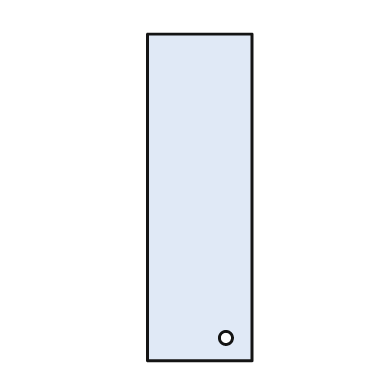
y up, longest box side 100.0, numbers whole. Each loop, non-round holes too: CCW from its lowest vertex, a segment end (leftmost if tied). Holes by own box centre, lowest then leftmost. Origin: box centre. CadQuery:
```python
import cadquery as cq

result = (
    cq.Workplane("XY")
    .moveTo(-16.0, -50.0)
    .lineTo(16.0, -50.0)
    .lineTo(16.0, 50.0)
    .lineTo(-16.0, 50.0)
    .close()
    .moveTo(8.0, -43.0)
    .circle(2.0)
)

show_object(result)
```